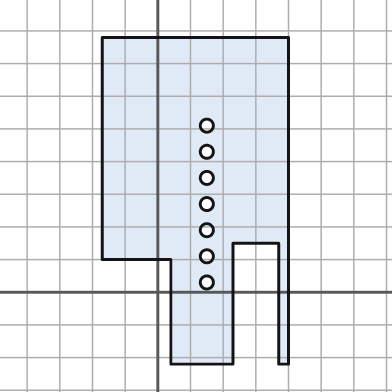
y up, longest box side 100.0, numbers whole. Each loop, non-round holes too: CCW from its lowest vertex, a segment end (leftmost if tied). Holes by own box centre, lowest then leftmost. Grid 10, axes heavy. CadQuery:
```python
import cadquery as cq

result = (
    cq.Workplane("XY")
    .moveTo(4.0, -22.0)
    .lineTo(23.0, -22.0)
    .lineTo(23.0, 15.0)
    .lineTo(37.0, 15.0)
    .lineTo(37.0, -22.0)
    .lineTo(40.0, -22.0)
    .lineTo(40.0, 78.0)
    .lineTo(-17.0, 78.0)
    .lineTo(-17.0, 10.0)
    .lineTo(4.0, 10.0)
    .close()
    .moveTo(15.0, 3.0)
    .circle(2.0)
    .moveTo(15.0, 11.0)
    .circle(2.0)
    .moveTo(15.0, 19.0)
    .circle(2.0)
    .moveTo(15.0, 27.0)
    .circle(2.0)
    .moveTo(15.0, 35.0)
    .circle(2.0)
    .moveTo(15.0, 43.0)
    .circle(2.0)
    .moveTo(15.0, 51.0)
    .circle(2.0)
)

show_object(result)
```